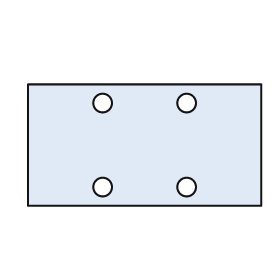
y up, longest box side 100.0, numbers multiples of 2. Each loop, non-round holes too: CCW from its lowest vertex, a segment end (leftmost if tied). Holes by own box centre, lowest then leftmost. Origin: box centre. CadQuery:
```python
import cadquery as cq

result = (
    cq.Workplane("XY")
    .moveTo(-50.0, -26.0)
    .lineTo(50.0, -26.0)
    .lineTo(50.0, 26.0)
    .lineTo(-50.0, 26.0)
    .close()
    .moveTo(-18.0, -18.0)
    .circle(4.0)
    .moveTo(18.0, -18.0)
    .circle(4.0)
    .moveTo(-18.0, 18.0)
    .circle(4.0)
    .moveTo(18.0, 18.0)
    .circle(4.0)
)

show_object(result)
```